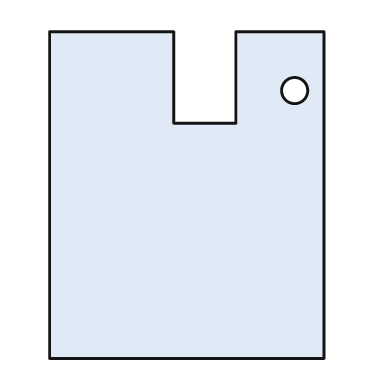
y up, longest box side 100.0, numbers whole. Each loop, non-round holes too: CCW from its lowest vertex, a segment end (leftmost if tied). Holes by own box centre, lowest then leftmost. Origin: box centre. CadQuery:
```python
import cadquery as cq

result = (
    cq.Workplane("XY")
    .moveTo(-42.0, -50.0)
    .lineTo(42.0, -50.0)
    .lineTo(42.0, 50.0)
    .lineTo(15.0, 50.0)
    .lineTo(15.0, 22.0)
    .lineTo(-4.0, 22.0)
    .lineTo(-4.0, 50.0)
    .lineTo(-42.0, 50.0)
    .close()
    .moveTo(33.0, 32.0)
    .circle(4.0)
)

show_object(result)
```